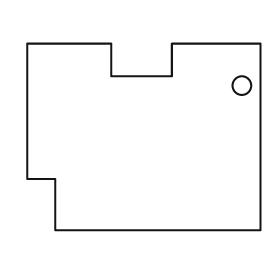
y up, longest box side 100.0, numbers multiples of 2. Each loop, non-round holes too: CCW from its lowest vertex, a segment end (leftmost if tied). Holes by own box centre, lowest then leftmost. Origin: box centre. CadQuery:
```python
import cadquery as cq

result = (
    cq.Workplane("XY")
    .moveTo(-38.0, -40.0)
    .lineTo(50.0, -40.0)
    .lineTo(50.0, 40.0)
    .lineTo(12.0, 40.0)
    .lineTo(12.0, 26.0)
    .lineTo(-14.0, 26.0)
    .lineTo(-14.0, 40.0)
    .lineTo(-50.0, 40.0)
    .lineTo(-50.0, -18.0)
    .lineTo(-38.0, -18.0)
    .close()
    .moveTo(42.0, 22.0)
    .circle(4.0)
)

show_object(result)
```